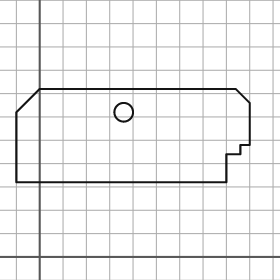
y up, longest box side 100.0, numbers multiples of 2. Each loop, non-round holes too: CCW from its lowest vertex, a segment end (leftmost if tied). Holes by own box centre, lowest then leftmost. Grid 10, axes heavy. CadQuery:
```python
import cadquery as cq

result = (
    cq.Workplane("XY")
    .moveTo(-10.0, 32.0)
    .lineTo(80.0, 32.0)
    .lineTo(80.0, 44.0)
    .lineTo(86.0, 44.0)
    .lineTo(86.0, 48.0)
    .lineTo(90.0, 48.0)
    .lineTo(90.0, 66.0)
    .lineTo(84.0, 72.0)
    .lineTo(0.0, 72.0)
    .lineTo(-10.0, 62.0)
    .close()
    .moveTo(36.0, 62.0)
    .circle(4.0)
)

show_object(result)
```